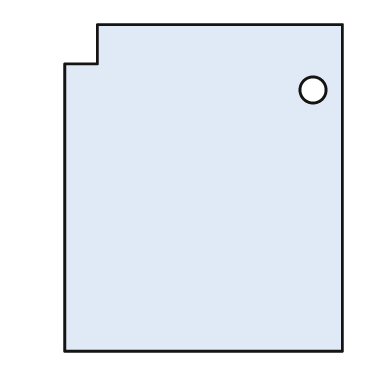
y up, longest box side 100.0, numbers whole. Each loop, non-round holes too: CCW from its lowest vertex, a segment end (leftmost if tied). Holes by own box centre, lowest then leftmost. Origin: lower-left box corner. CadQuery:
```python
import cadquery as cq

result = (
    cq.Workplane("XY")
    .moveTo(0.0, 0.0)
    .lineTo(85.0, 0.0)
    .lineTo(85.0, 100.0)
    .lineTo(10.0, 100.0)
    .lineTo(10.0, 88.0)
    .lineTo(0.0, 88.0)
    .close()
    .moveTo(76.0, 80.0)
    .circle(4.0)
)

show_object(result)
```